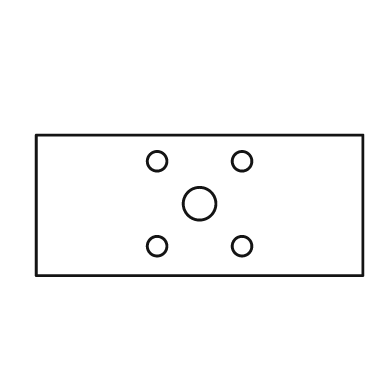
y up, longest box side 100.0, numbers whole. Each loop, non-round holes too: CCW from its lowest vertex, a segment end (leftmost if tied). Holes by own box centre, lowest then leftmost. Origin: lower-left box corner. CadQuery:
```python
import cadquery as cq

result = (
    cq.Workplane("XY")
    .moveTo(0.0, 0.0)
    .lineTo(100.0, 0.0)
    .lineTo(100.0, 43.0)
    .lineTo(0.0, 43.0)
    .close()
    .moveTo(37.0, 9.0)
    .circle(3.0)
    .moveTo(63.0, 9.0)
    .circle(3.0)
    .moveTo(50.0, 22.0)
    .circle(5.0)
    .moveTo(37.0, 35.0)
    .circle(3.0)
    .moveTo(63.0, 35.0)
    .circle(3.0)
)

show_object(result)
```